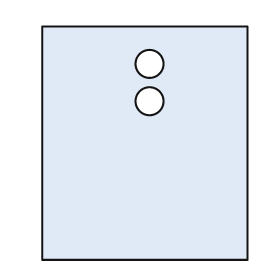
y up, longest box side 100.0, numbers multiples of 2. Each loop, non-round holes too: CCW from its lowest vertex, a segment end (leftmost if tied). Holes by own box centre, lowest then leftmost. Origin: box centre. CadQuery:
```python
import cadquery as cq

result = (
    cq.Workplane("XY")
    .moveTo(-44.0, -50.0)
    .lineTo(44.0, -50.0)
    .lineTo(44.0, 50.0)
    .lineTo(-44.0, 50.0)
    .close()
    .moveTo(2.0, 18.0)
    .circle(6.0)
    .moveTo(2.0, 34.0)
    .circle(6.0)
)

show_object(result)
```